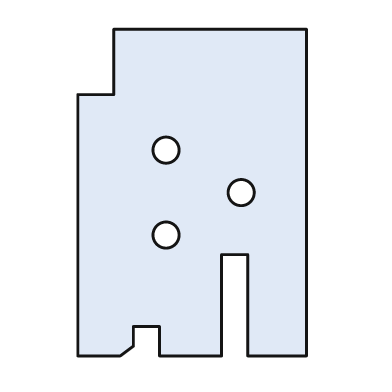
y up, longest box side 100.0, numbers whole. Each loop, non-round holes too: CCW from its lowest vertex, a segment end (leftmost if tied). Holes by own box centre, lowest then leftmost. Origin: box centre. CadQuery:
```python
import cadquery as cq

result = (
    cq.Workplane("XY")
    .moveTo(-35.0, -50.0)
    .lineTo(-22.0, -50.0)
    .lineTo(-18.0, -47.0)
    .lineTo(-18.0, -41.0)
    .lineTo(-10.0, -41.0)
    .lineTo(-10.0, -50.0)
    .lineTo(9.0, -50.0)
    .lineTo(9.0, -19.0)
    .lineTo(17.0, -19.0)
    .lineTo(17.0, -50.0)
    .lineTo(35.0, -50.0)
    .lineTo(35.0, 50.0)
    .lineTo(-24.0, 50.0)
    .lineTo(-24.0, 30.0)
    .lineTo(-35.0, 30.0)
    .close()
    .moveTo(-8.0, -13.0)
    .circle(4.0)
    .moveTo(15.0, 0.0)
    .circle(4.0)
    .moveTo(-8.0, 13.0)
    .circle(4.0)
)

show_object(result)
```